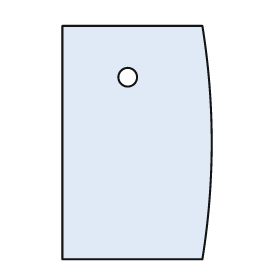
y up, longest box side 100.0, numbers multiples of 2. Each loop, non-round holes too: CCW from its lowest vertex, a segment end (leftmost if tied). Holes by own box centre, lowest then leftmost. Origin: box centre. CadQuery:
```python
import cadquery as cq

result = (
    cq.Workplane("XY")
    .moveTo(-32.0, -50.0)
    .lineTo(28.0, -50.0)
    .threePointArc((32.0, 0.0), (28.0, 50.0))
    .lineTo(-32.0, 50.0)
    .close()
    .moveTo(-4.0, 28.0)
    .circle(4.0)
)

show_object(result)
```